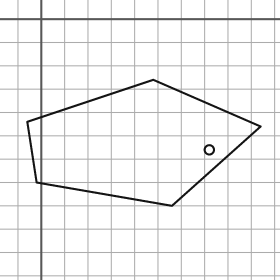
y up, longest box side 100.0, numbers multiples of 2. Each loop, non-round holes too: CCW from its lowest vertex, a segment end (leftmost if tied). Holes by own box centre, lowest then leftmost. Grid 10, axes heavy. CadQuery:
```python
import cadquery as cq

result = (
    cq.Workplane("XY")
    .moveTo(56.0, -80.0)
    .lineTo(94.0, -46.0)
    .lineTo(48.0, -26.0)
    .lineTo(-6.0, -44.0)
    .lineTo(-2.0, -70.0)
    .close()
    .moveTo(72.0, -56.0)
    .circle(2.0)
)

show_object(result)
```